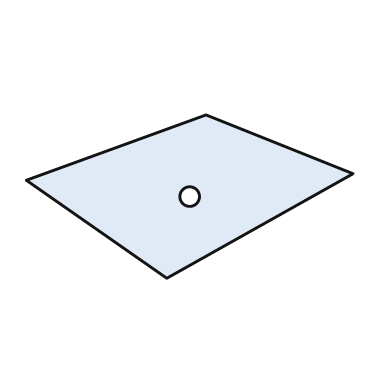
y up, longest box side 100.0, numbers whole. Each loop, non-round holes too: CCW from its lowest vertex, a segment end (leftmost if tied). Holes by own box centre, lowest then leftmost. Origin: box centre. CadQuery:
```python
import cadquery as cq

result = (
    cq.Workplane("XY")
    .moveTo(-7.0, -25.0)
    .lineTo(50.0, 7.0)
    .lineTo(5.0, 25.0)
    .lineTo(-50.0, 5.0)
    .close()
    .moveTo(0.0, 0.0)
    .circle(3.0)
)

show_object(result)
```